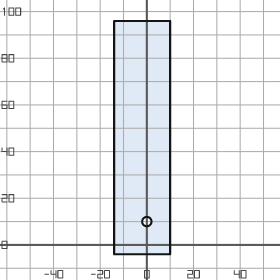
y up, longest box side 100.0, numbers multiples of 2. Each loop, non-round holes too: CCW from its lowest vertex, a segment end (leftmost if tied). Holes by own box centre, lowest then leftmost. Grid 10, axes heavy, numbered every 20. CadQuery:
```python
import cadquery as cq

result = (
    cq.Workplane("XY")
    .moveTo(-14.0, -4.0)
    .lineTo(10.0, -4.0)
    .lineTo(10.0, 96.0)
    .lineTo(-14.0, 96.0)
    .close()
    .moveTo(0.0, 10.0)
    .circle(2.0)
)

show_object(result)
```